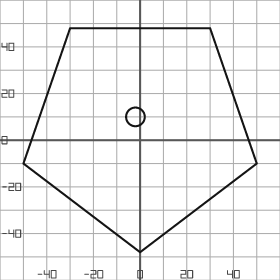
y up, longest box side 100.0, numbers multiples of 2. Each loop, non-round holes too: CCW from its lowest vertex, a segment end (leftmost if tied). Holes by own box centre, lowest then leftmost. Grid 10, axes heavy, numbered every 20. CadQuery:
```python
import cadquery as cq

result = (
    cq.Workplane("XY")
    .moveTo(0.0, -48.0)
    .lineTo(50.0, -10.0)
    .lineTo(30.0, 48.0)
    .lineTo(-30.0, 48.0)
    .lineTo(-50.0, -10.0)
    .close()
    .moveTo(-2.0, 10.0)
    .circle(4.0)
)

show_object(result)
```